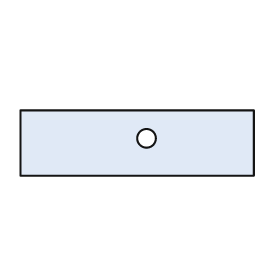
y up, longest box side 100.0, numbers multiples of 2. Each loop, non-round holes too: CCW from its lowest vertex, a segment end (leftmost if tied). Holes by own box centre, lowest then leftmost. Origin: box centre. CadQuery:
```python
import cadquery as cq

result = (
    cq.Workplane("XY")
    .moveTo(-50.0, -14.0)
    .lineTo(50.0, -14.0)
    .lineTo(50.0, 14.0)
    .lineTo(-50.0, 14.0)
    .close()
    .moveTo(4.0, 2.0)
    .circle(4.0)
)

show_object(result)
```